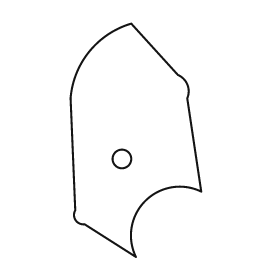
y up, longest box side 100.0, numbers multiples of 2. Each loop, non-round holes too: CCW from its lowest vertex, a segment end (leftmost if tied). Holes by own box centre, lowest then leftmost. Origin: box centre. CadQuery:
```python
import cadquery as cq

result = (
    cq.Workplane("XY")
    .moveTo(0.0, -50.0)
    .threePointArc((4.0, -26.0), (28.0, -22.0))
    .lineTo(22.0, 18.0)
    .threePointArc((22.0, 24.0), (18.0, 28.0))
    .lineTo(-2.0, 50.0)
    .threePointArc((-20.0, 38.0), (-28.0, 18.0))
    .lineTo(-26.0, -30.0)
    .threePointArc((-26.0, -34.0), (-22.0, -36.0))
    .close()
    .moveTo(-6.0, -8.0)
    .circle(4.0)
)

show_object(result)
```